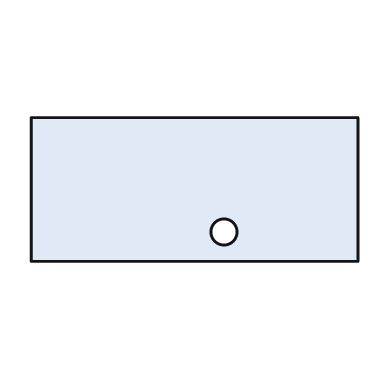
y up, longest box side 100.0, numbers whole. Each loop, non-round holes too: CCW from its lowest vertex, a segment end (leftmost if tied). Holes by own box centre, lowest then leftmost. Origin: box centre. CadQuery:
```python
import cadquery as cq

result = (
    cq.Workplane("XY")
    .moveTo(-50.0, -22.0)
    .lineTo(50.0, -22.0)
    .lineTo(50.0, 22.0)
    .lineTo(-50.0, 22.0)
    .close()
    .moveTo(9.0, -13.0)
    .circle(4.0)
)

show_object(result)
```